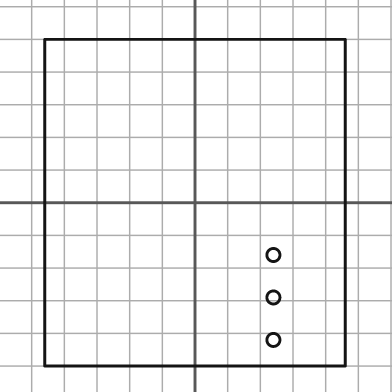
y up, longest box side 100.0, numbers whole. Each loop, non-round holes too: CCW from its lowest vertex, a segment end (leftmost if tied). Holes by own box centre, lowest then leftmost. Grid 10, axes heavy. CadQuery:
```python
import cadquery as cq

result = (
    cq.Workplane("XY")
    .moveTo(-46.0, -50.0)
    .lineTo(46.0, -50.0)
    .lineTo(46.0, 50.0)
    .lineTo(-46.0, 50.0)
    .close()
    .moveTo(24.0, -42.0)
    .circle(2.0)
    .moveTo(24.0, -29.0)
    .circle(2.0)
    .moveTo(24.0, -16.0)
    .circle(2.0)
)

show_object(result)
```